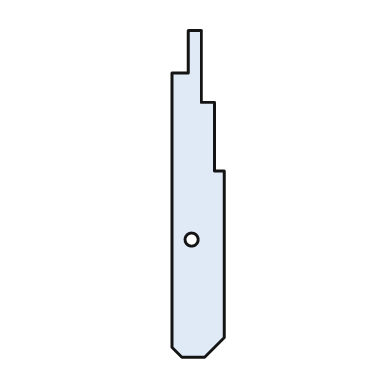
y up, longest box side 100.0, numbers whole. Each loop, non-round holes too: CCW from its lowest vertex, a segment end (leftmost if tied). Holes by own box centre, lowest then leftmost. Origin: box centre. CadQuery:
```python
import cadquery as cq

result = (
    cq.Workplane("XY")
    .moveTo(-5.0, -50.0)
    .lineTo(2.0, -50.0)
    .lineTo(8.0, -44.0)
    .lineTo(8.0, 7.0)
    .lineTo(5.0, 7.0)
    .lineTo(5.0, 28.0)
    .lineTo(1.0, 28.0)
    .lineTo(1.0, 50.0)
    .lineTo(-3.0, 50.0)
    .lineTo(-3.0, 37.0)
    .lineTo(-8.0, 37.0)
    .lineTo(-8.0, -47.0)
    .close()
    .moveTo(-2.0, -14.0)
    .circle(2.0)
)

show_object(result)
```